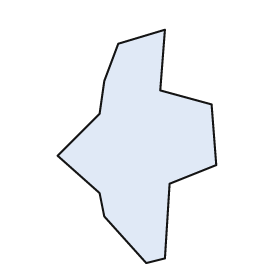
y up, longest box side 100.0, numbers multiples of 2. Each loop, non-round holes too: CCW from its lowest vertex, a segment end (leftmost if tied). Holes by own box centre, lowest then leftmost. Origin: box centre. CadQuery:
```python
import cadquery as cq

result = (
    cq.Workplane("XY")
    .moveTo(4.0, -50.0)
    .lineTo(12.0, -48.0)
    .lineTo(14.0, -16.0)
    .lineTo(34.0, -8.0)
    .lineTo(32.0, 18.0)
    .lineTo(10.0, 24.0)
    .lineTo(12.0, 50.0)
    .lineTo(-8.0, 44.0)
    .lineTo(-14.0, 28.0)
    .lineTo(-16.0, 14.0)
    .lineTo(-34.0, -4.0)
    .lineTo(-16.0, -20.0)
    .lineTo(-14.0, -30.0)
    .close()
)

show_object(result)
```